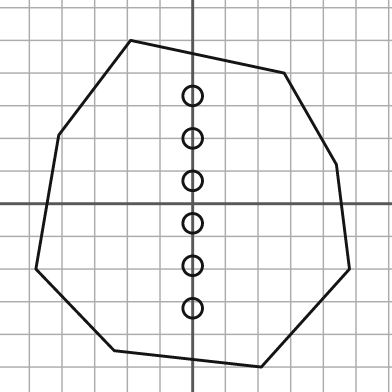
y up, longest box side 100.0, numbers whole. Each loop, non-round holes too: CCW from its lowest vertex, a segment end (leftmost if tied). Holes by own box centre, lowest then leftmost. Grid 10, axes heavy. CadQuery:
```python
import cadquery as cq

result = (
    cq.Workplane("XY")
    .moveTo(21.0, -50.0)
    .lineTo(48.0, -20.0)
    .lineTo(44.0, 12.0)
    .lineTo(28.0, 40.0)
    .lineTo(-19.0, 50.0)
    .lineTo(-41.0, 21.0)
    .lineTo(-48.0, -20.0)
    .lineTo(-24.0, -45.0)
    .close()
    .moveTo(0.0, -32.0)
    .circle(3.0)
    .moveTo(0.0, -19.0)
    .circle(3.0)
    .moveTo(0.0, -6.0)
    .circle(3.0)
    .moveTo(0.0, 7.0)
    .circle(3.0)
    .moveTo(0.0, 20.0)
    .circle(3.0)
    .moveTo(0.0, 33.0)
    .circle(3.0)
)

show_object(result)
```